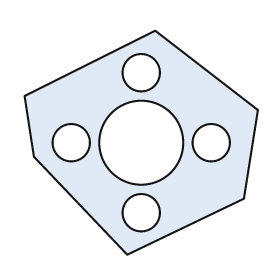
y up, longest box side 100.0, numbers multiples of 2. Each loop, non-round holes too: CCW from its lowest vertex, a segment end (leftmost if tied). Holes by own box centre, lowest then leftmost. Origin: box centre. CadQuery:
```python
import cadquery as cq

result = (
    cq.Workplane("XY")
    .moveTo(-6.0, -48.0)
    .lineTo(44.0, -24.0)
    .lineTo(50.0, 14.0)
    .lineTo(6.0, 48.0)
    .lineTo(-50.0, 20.0)
    .lineTo(-46.0, -6.0)
    .close()
    .moveTo(0.0, -30.0)
    .circle(8.0)
    .moveTo(-30.0, 0.0)
    .circle(8.0)
    .moveTo(0.0, 0.0)
    .circle(18.0)
    .moveTo(30.0, 0.0)
    .circle(8.0)
    .moveTo(0.0, 30.0)
    .circle(8.0)
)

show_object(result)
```